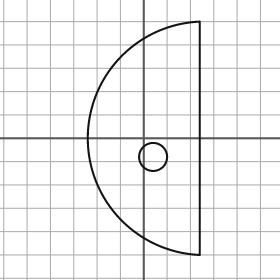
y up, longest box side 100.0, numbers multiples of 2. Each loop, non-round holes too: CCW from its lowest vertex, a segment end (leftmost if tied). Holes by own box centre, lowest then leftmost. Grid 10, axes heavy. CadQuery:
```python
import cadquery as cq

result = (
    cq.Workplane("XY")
    .moveTo(24.0, -50.0)
    .lineTo(24.0, 50.0)
    .threePointArc((-24.0, 0.0), (24.0, -50.0))
    .close()
    .moveTo(4.0, -8.0)
    .circle(6.0)
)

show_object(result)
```